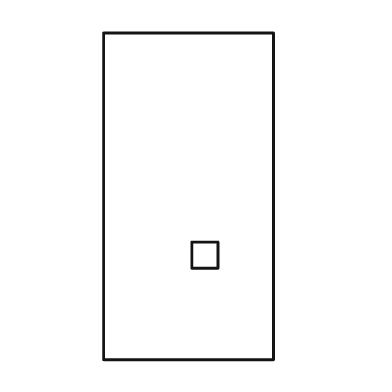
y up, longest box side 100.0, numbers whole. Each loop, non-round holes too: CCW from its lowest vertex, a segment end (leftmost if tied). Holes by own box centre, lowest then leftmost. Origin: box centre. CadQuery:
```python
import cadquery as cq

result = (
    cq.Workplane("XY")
    .moveTo(-26.0, -50.0)
    .lineTo(26.0, -50.0)
    .lineTo(26.0, 50.0)
    .lineTo(-26.0, 50.0)
    .close()
    .moveTo(1.0, -22.0)
    .lineTo(9.0, -22.0)
    .lineTo(9.0, -14.0)
    .lineTo(1.0, -14.0)
    .close()
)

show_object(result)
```